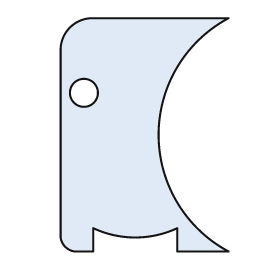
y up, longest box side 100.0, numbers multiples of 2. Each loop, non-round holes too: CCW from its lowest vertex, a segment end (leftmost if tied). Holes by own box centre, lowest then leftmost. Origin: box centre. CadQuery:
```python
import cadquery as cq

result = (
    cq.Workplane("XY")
    .moveTo(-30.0, -50.0)
    .lineTo(-22.0, -50.0)
    .lineTo(-22.0, -40.0)
    .threePointArc((-4.0, -44.0), (14.0, -40.0))
    .lineTo(14.0, -50.0)
    .lineTo(36.0, -50.0)
    .threePointArc((6.0, 0.0), (36.0, 50.0))
    .lineTo(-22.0, 50.0)
    .threePointArc((-32.0, 46.0), (-36.0, 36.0))
    .lineTo(-36.0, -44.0)
    .threePointArc((-34.0, -48.0), (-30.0, -50.0))
    .close()
    .moveTo(-26.0, 18.0)
    .circle(6.0)
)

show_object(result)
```